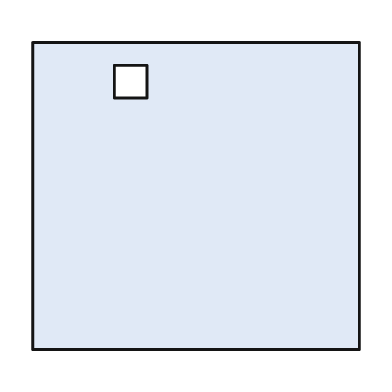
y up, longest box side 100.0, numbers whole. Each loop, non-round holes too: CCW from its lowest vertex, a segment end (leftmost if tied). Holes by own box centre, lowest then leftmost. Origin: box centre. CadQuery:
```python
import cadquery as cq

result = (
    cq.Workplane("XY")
    .moveTo(-50.0, -47.0)
    .lineTo(50.0, -47.0)
    .lineTo(50.0, 47.0)
    .lineTo(-50.0, 47.0)
    .close()
    .moveTo(-25.0, 30.0)
    .lineTo(-15.0, 30.0)
    .lineTo(-15.0, 40.0)
    .lineTo(-25.0, 40.0)
    .close()
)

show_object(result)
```